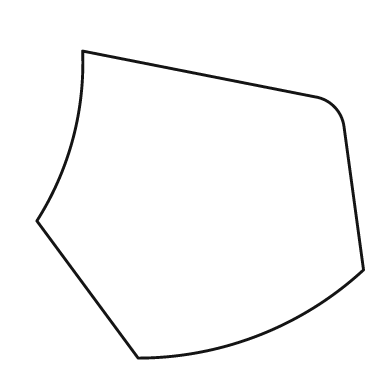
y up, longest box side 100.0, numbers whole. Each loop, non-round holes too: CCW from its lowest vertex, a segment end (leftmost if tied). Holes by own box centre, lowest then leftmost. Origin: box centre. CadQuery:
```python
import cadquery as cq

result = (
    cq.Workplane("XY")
    .moveTo(-19.0, -47.0)
    .threePointArc((18.0, -40.0), (50.0, -20.0))
    .lineTo(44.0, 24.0)
    .threePointArc((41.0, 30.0), (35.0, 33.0))
    .lineTo(-36.0, 47.0)
    .threePointArc((-39.0, 20.0), (-50.0, -5.0))
    .close()
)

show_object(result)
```